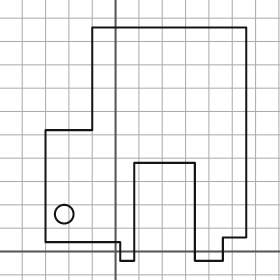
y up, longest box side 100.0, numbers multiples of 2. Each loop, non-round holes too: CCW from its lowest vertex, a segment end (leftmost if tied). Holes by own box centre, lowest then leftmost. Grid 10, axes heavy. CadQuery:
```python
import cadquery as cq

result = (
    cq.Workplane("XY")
    .moveTo(2.0, -4.0)
    .lineTo(8.0, -4.0)
    .lineTo(8.0, 38.0)
    .lineTo(34.0, 38.0)
    .lineTo(34.0, -4.0)
    .lineTo(46.0, -4.0)
    .lineTo(46.0, 6.0)
    .lineTo(56.0, 6.0)
    .lineTo(56.0, 96.0)
    .lineTo(-10.0, 96.0)
    .lineTo(-10.0, 52.0)
    .lineTo(-30.0, 52.0)
    .lineTo(-30.0, 4.0)
    .lineTo(2.0, 4.0)
    .close()
    .moveTo(-22.0, 16.0)
    .circle(4.0)
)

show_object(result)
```